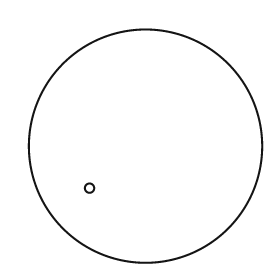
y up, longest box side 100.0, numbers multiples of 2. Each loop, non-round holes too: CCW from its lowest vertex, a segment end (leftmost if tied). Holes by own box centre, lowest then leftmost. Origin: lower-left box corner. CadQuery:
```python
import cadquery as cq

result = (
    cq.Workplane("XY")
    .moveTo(50.0, 50.0)
    .circle(50.0)
    .moveTo(26.0, 32.0)
    .circle(2.0)
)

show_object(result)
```